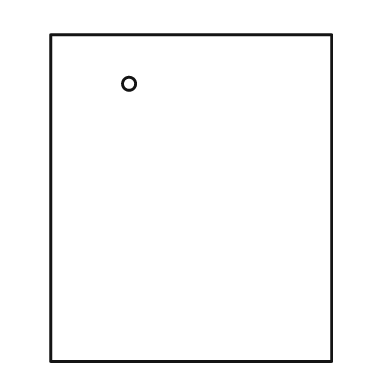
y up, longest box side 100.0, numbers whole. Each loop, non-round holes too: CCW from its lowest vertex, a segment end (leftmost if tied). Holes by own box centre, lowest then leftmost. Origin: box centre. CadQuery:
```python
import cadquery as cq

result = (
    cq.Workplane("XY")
    .moveTo(-43.0, -50.0)
    .lineTo(43.0, -50.0)
    .lineTo(43.0, 50.0)
    .lineTo(-43.0, 50.0)
    .close()
    .moveTo(-19.0, 35.0)
    .circle(2.0)
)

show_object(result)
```